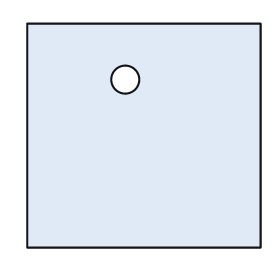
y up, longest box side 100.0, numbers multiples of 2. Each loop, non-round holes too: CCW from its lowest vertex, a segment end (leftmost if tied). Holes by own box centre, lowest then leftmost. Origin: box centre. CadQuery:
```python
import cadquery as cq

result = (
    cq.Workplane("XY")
    .moveTo(-50.0, -48.0)
    .lineTo(50.0, -48.0)
    .lineTo(50.0, 48.0)
    .lineTo(-50.0, 48.0)
    .close()
    .moveTo(-8.0, 24.0)
    .circle(6.0)
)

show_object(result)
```